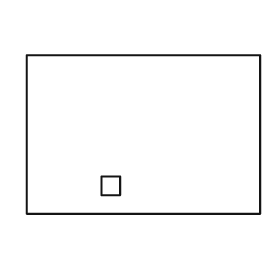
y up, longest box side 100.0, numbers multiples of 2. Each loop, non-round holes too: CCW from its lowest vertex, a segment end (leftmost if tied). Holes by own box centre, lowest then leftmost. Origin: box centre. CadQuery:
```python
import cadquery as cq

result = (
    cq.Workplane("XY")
    .moveTo(-50.0, -34.0)
    .lineTo(50.0, -34.0)
    .lineTo(50.0, 34.0)
    .lineTo(-50.0, 34.0)
    .close()
    .moveTo(-18.0, -26.0)
    .lineTo(-10.0, -26.0)
    .lineTo(-10.0, -18.0)
    .lineTo(-18.0, -18.0)
    .close()
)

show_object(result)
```